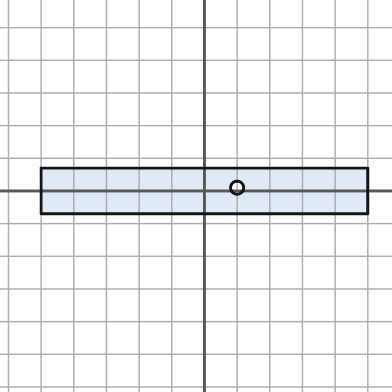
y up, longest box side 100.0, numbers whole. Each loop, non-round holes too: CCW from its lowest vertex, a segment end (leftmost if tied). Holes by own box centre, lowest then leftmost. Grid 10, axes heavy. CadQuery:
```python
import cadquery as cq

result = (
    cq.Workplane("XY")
    .moveTo(-50.0, -7.0)
    .lineTo(50.0, -7.0)
    .lineTo(50.0, 7.0)
    .lineTo(-50.0, 7.0)
    .close()
    .moveTo(10.0, 1.0)
    .circle(2.0)
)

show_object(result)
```